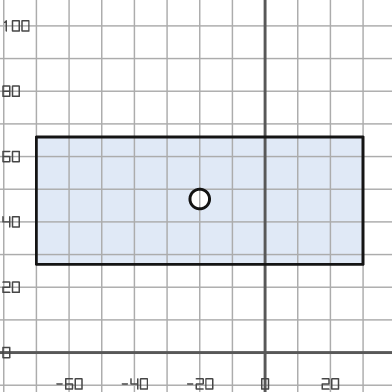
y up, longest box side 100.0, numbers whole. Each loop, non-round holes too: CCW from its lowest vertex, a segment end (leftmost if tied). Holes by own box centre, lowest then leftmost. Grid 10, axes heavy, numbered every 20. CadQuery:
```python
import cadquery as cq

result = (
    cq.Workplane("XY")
    .moveTo(-70.0, 27.0)
    .lineTo(30.0, 27.0)
    .lineTo(30.0, 66.0)
    .lineTo(-70.0, 66.0)
    .close()
    .moveTo(-20.0, 47.0)
    .circle(3.0)
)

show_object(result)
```